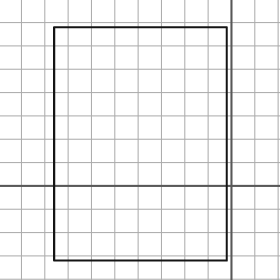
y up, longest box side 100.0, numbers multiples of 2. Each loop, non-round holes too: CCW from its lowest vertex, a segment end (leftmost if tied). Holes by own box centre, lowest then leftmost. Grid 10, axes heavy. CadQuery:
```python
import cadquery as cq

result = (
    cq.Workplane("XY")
    .moveTo(-76.0, -32.0)
    .lineTo(-2.0, -32.0)
    .lineTo(-2.0, 68.0)
    .lineTo(-76.0, 68.0)
    .close()
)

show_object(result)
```